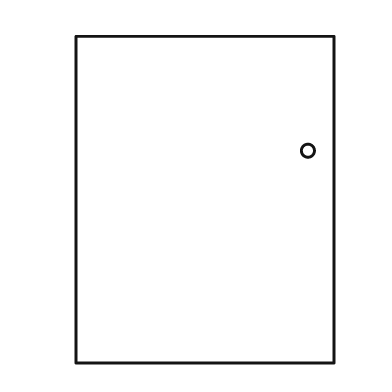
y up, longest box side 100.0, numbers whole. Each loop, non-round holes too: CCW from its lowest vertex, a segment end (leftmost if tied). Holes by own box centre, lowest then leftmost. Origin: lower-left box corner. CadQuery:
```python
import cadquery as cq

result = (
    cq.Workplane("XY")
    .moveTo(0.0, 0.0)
    .lineTo(79.0, 0.0)
    .lineTo(79.0, 100.0)
    .lineTo(0.0, 100.0)
    .close()
    .moveTo(71.0, 65.0)
    .circle(2.0)
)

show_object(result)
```